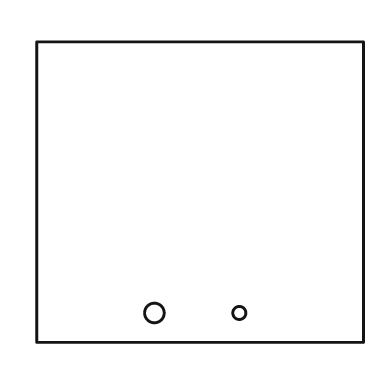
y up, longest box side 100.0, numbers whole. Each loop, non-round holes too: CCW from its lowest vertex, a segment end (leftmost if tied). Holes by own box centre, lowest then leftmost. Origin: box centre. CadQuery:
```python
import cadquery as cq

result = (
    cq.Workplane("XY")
    .moveTo(-50.0, -46.0)
    .lineTo(50.0, -46.0)
    .lineTo(50.0, 46.0)
    .lineTo(-50.0, 46.0)
    .close()
    .moveTo(-14.0, -37.0)
    .circle(3.0)
    .moveTo(12.0, -37.0)
    .circle(2.0)
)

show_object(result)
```